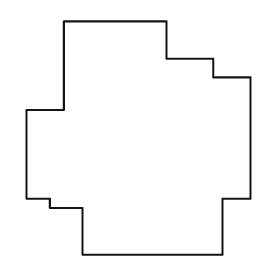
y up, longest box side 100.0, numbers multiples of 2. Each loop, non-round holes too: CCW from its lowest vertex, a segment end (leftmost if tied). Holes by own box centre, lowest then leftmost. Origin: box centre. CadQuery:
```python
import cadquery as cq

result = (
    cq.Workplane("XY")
    .moveTo(-24.0, -50.0)
    .lineTo(36.0, -50.0)
    .lineTo(36.0, -26.0)
    .lineTo(48.0, -26.0)
    .lineTo(48.0, 26.0)
    .lineTo(32.0, 26.0)
    .lineTo(32.0, 34.0)
    .lineTo(12.0, 34.0)
    .lineTo(12.0, 50.0)
    .lineTo(-32.0, 50.0)
    .lineTo(-32.0, 12.0)
    .lineTo(-48.0, 12.0)
    .lineTo(-48.0, -26.0)
    .lineTo(-38.0, -26.0)
    .lineTo(-38.0, -30.0)
    .lineTo(-24.0, -30.0)
    .close()
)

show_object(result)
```